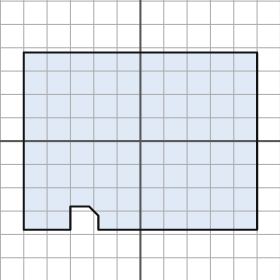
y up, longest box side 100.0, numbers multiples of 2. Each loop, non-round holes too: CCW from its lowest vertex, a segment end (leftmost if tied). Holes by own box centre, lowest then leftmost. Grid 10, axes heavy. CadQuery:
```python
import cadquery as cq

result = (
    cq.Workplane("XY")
    .moveTo(-50.0, -38.0)
    .lineTo(-30.0, -38.0)
    .lineTo(-30.0, -28.0)
    .lineTo(-22.0, -28.0)
    .lineTo(-18.0, -32.0)
    .lineTo(-18.0, -38.0)
    .lineTo(50.0, -38.0)
    .lineTo(50.0, 38.0)
    .lineTo(-50.0, 38.0)
    .close()
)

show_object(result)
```